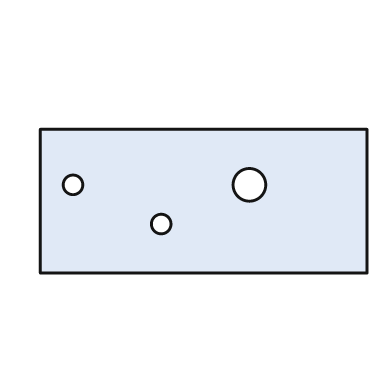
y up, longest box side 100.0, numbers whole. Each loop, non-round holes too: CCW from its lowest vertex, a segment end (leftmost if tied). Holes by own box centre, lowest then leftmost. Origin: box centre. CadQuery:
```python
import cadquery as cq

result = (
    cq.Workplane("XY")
    .moveTo(-50.0, -22.0)
    .lineTo(50.0, -22.0)
    .lineTo(50.0, 22.0)
    .lineTo(-50.0, 22.0)
    .close()
    .moveTo(-13.0, -7.0)
    .circle(3.0)
    .moveTo(-40.0, 5.0)
    .circle(3.0)
    .moveTo(14.0, 5.0)
    .circle(5.0)
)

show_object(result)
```